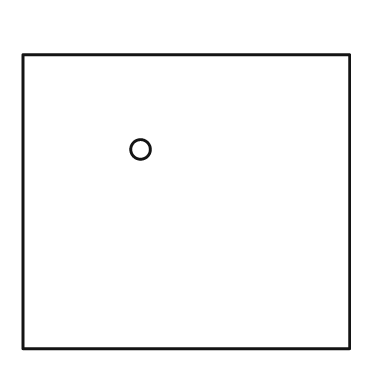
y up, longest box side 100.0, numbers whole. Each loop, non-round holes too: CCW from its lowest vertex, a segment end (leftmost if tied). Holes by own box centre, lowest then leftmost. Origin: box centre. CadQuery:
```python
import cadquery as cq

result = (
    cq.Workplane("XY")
    .moveTo(-50.0, -45.0)
    .lineTo(50.0, -45.0)
    .lineTo(50.0, 45.0)
    .lineTo(-50.0, 45.0)
    .close()
    .moveTo(-14.0, 16.0)
    .circle(3.0)
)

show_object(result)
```